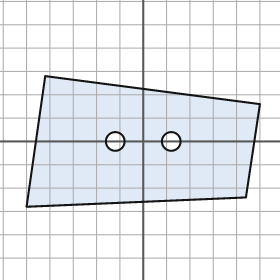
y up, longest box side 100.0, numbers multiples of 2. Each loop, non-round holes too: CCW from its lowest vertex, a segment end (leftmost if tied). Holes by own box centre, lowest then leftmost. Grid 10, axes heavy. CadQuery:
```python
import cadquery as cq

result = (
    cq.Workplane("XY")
    .moveTo(-50.0, -28.0)
    .lineTo(44.0, -24.0)
    .lineTo(50.0, 16.0)
    .lineTo(-42.0, 28.0)
    .close()
    .moveTo(-12.0, 0.0)
    .circle(4.0)
    .moveTo(12.0, 0.0)
    .circle(4.0)
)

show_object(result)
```